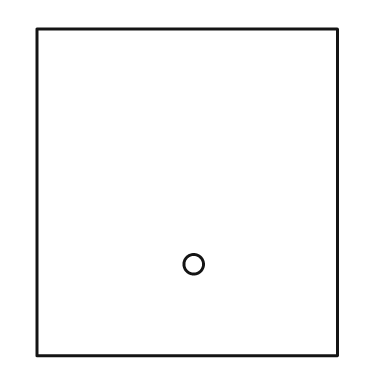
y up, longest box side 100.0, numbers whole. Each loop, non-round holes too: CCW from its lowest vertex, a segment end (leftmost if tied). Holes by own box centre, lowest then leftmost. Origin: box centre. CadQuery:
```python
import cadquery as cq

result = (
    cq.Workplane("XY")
    .moveTo(-46.0, -50.0)
    .lineTo(46.0, -50.0)
    .lineTo(46.0, 50.0)
    .lineTo(-46.0, 50.0)
    .close()
    .moveTo(2.0, -22.0)
    .circle(3.0)
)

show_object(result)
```